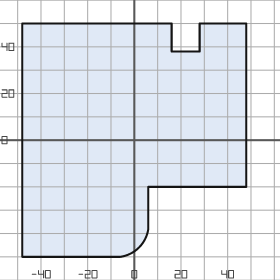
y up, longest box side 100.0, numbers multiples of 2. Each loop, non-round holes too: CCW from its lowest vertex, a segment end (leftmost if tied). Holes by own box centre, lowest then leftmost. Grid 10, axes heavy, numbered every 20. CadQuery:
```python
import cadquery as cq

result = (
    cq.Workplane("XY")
    .moveTo(-48.0, -50.0)
    .lineTo(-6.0, -50.0)
    .threePointArc((2.0, -46.0), (6.0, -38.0))
    .lineTo(6.0, -20.0)
    .lineTo(48.0, -20.0)
    .lineTo(48.0, 50.0)
    .lineTo(28.0, 50.0)
    .lineTo(28.0, 38.0)
    .lineTo(16.0, 38.0)
    .lineTo(16.0, 50.0)
    .lineTo(-48.0, 50.0)
    .close()
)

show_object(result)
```